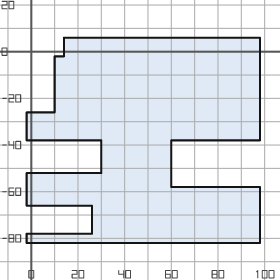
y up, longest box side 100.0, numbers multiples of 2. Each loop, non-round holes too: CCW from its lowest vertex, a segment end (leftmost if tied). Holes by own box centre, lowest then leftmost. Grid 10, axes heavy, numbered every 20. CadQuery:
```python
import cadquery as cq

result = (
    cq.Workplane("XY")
    .moveTo(-2.0, -82.0)
    .lineTo(98.0, -82.0)
    .lineTo(98.0, -58.0)
    .lineTo(60.0, -58.0)
    .lineTo(60.0, -38.0)
    .lineTo(98.0, -38.0)
    .lineTo(98.0, 6.0)
    .lineTo(14.0, 6.0)
    .lineTo(14.0, -2.0)
    .lineTo(10.0, -2.0)
    .lineTo(10.0, -26.0)
    .lineTo(-2.0, -26.0)
    .lineTo(-2.0, -38.0)
    .lineTo(30.0, -38.0)
    .lineTo(30.0, -52.0)
    .lineTo(-2.0, -52.0)
    .lineTo(-2.0, -66.0)
    .lineTo(26.0, -66.0)
    .lineTo(26.0, -78.0)
    .lineTo(-2.0, -78.0)
    .close()
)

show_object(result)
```